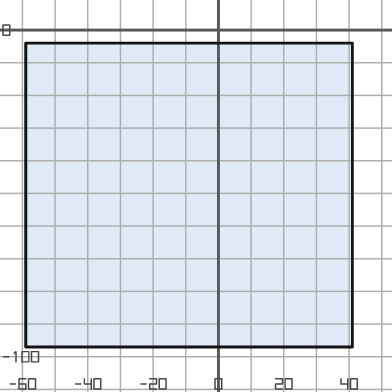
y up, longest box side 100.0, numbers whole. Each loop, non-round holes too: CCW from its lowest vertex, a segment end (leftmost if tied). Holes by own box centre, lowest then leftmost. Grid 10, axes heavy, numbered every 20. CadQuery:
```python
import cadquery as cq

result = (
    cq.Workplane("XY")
    .moveTo(-59.0, -97.0)
    .lineTo(41.0, -97.0)
    .lineTo(41.0, -4.0)
    .lineTo(-59.0, -4.0)
    .close()
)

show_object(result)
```